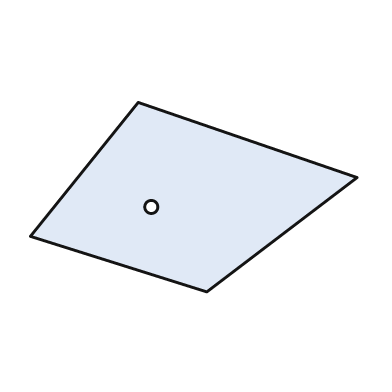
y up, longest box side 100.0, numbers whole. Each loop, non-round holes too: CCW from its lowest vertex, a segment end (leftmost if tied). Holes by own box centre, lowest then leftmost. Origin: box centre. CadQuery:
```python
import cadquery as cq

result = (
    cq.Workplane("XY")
    .moveTo(4.0, -29.0)
    .lineTo(50.0, 6.0)
    .lineTo(-17.0, 29.0)
    .lineTo(-50.0, -12.0)
    .close()
    .moveTo(-13.0, -3.0)
    .circle(2.0)
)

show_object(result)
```